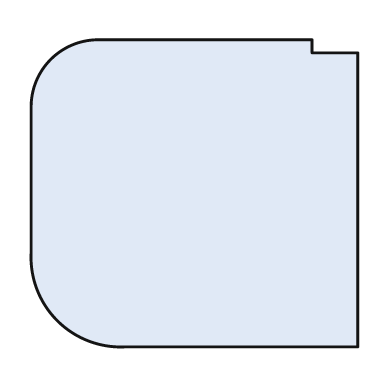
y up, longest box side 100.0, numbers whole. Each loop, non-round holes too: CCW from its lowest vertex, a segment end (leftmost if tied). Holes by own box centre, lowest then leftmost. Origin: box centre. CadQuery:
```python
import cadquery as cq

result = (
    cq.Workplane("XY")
    .moveTo(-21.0, -47.0)
    .lineTo(50.0, -47.0)
    .lineTo(50.0, 43.0)
    .lineTo(36.0, 43.0)
    .lineTo(36.0, 47.0)
    .lineTo(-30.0, 47.0)
    .threePointArc((-44.0, 41.0), (-50.0, 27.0))
    .lineTo(-50.0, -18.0)
    .threePointArc((-42.0, -39.0), (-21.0, -47.0))
    .close()
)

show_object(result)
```